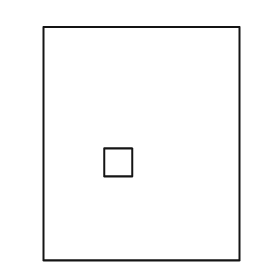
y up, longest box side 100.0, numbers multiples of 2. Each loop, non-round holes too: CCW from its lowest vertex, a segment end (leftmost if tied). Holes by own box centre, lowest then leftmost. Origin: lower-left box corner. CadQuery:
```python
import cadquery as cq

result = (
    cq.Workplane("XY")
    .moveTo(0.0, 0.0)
    .lineTo(84.0, 0.0)
    .lineTo(84.0, 100.0)
    .lineTo(0.0, 100.0)
    .close()
    .moveTo(26.0, 36.0)
    .lineTo(38.0, 36.0)
    .lineTo(38.0, 48.0)
    .lineTo(26.0, 48.0)
    .close()
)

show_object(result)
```